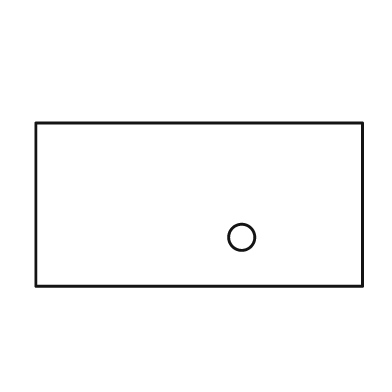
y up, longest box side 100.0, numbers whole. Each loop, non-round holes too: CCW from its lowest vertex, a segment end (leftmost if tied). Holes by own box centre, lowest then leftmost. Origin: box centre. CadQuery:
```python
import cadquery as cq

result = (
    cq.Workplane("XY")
    .moveTo(-50.0, -25.0)
    .lineTo(50.0, -25.0)
    .lineTo(50.0, 25.0)
    .lineTo(-50.0, 25.0)
    .close()
    .moveTo(13.0, -10.0)
    .circle(4.0)
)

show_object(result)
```